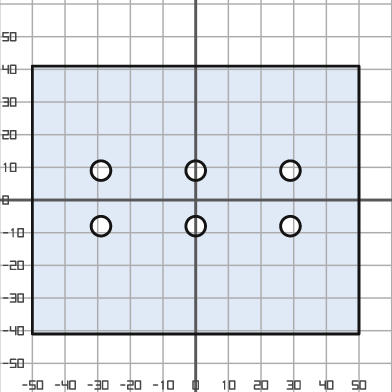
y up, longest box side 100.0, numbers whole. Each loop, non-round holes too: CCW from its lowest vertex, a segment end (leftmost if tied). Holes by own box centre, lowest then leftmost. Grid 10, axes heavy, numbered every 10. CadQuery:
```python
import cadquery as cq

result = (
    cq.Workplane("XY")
    .moveTo(-50.0, -41.0)
    .lineTo(50.0, -41.0)
    .lineTo(50.0, 41.0)
    .lineTo(-50.0, 41.0)
    .close()
    .moveTo(-29.0, -8.0)
    .circle(3.0)
    .moveTo(0.0, -8.0)
    .circle(3.0)
    .moveTo(29.0, -8.0)
    .circle(3.0)
    .moveTo(-29.0, 9.0)
    .circle(3.0)
    .moveTo(0.0, 9.0)
    .circle(3.0)
    .moveTo(29.0, 9.0)
    .circle(3.0)
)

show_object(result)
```